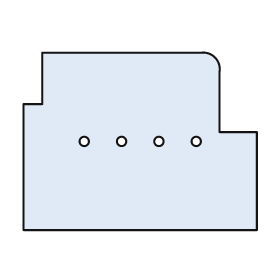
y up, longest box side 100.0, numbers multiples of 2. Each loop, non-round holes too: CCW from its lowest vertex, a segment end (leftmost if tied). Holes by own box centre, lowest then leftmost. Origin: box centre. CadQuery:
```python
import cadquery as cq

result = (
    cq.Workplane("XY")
    .moveTo(-50.0, -38.0)
    .lineTo(50.0, -38.0)
    .lineTo(50.0, 4.0)
    .lineTo(34.0, 4.0)
    .lineTo(34.0, 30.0)
    .threePointArc((32.0, 36.0), (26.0, 38.0))
    .lineTo(-42.0, 38.0)
    .lineTo(-42.0, 16.0)
    .lineTo(-50.0, 16.0)
    .close()
    .moveTo(-24.0, 0.0)
    .circle(2.0)
    .moveTo(-8.0, 0.0)
    .circle(2.0)
    .moveTo(8.0, 0.0)
    .circle(2.0)
    .moveTo(24.0, 0.0)
    .circle(2.0)
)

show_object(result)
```